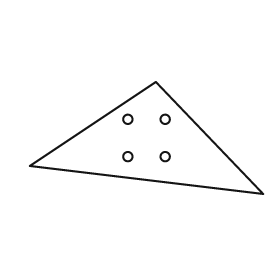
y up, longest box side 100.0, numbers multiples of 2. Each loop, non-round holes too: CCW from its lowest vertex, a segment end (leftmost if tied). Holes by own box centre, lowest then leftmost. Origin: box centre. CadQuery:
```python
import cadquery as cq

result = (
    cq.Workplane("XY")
    .moveTo(50.0, -24.0)
    .lineTo(4.0, 24.0)
    .lineTo(-50.0, -12.0)
    .close()
    .moveTo(-8.0, -8.0)
    .circle(2.0)
    .moveTo(8.0, -8.0)
    .circle(2.0)
    .moveTo(-8.0, 8.0)
    .circle(2.0)
    .moveTo(8.0, 8.0)
    .circle(2.0)
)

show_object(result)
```